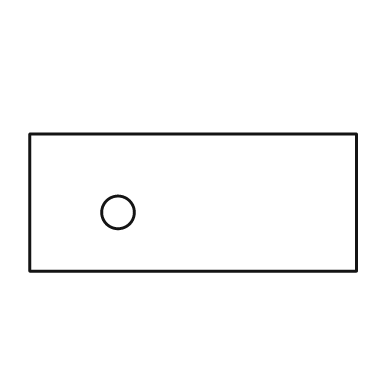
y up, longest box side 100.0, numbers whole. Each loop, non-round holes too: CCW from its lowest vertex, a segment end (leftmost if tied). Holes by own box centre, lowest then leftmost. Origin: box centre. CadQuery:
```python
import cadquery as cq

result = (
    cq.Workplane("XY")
    .moveTo(-50.0, -21.0)
    .lineTo(50.0, -21.0)
    .lineTo(50.0, 21.0)
    .lineTo(-50.0, 21.0)
    .close()
    .moveTo(-23.0, -3.0)
    .circle(5.0)
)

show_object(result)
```